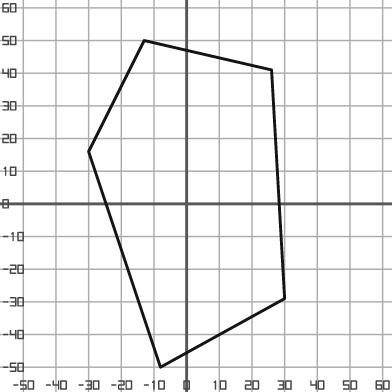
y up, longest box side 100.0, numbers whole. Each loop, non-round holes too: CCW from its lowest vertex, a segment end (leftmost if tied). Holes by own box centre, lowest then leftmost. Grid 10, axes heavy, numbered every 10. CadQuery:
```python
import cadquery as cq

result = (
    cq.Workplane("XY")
    .moveTo(-8.0, -50.0)
    .lineTo(30.0, -29.0)
    .lineTo(26.0, 41.0)
    .lineTo(-13.0, 50.0)
    .lineTo(-30.0, 16.0)
    .close()
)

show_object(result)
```